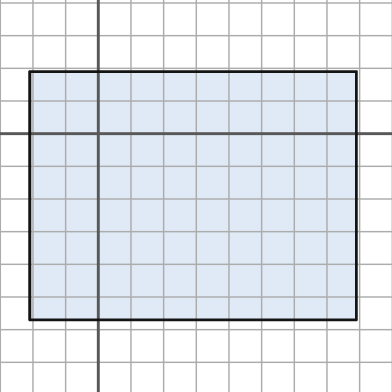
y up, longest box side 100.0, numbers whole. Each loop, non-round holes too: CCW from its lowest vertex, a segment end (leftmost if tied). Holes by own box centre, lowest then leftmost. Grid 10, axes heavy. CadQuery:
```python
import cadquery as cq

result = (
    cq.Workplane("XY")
    .moveTo(-21.0, -57.0)
    .lineTo(79.0, -57.0)
    .lineTo(79.0, 19.0)
    .lineTo(-21.0, 19.0)
    .close()
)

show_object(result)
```